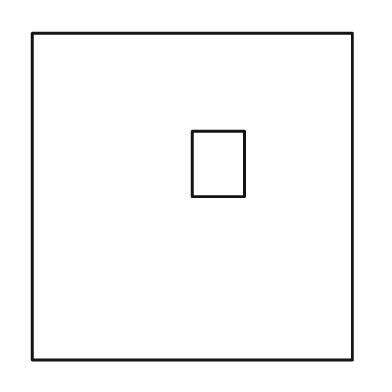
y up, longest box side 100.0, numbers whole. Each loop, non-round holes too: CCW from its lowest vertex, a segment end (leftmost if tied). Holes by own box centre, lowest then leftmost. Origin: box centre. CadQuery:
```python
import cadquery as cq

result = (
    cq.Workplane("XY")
    .moveTo(-49.0, -50.0)
    .lineTo(49.0, -50.0)
    .lineTo(49.0, 50.0)
    .lineTo(-49.0, 50.0)
    .close()
    .moveTo(0.0, 0.0)
    .lineTo(16.0, 0.0)
    .lineTo(16.0, 20.0)
    .lineTo(0.0, 20.0)
    .close()
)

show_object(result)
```